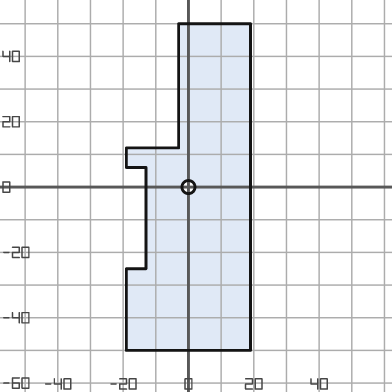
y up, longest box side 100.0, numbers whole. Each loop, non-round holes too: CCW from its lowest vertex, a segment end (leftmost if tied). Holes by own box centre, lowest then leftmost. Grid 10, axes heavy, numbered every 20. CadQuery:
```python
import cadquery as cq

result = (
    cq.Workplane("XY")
    .moveTo(-19.0, -50.0)
    .lineTo(19.0, -50.0)
    .lineTo(19.0, 50.0)
    .lineTo(-3.0, 50.0)
    .lineTo(-3.0, 12.0)
    .lineTo(-19.0, 12.0)
    .lineTo(-19.0, 6.0)
    .lineTo(-13.0, 6.0)
    .lineTo(-13.0, -25.0)
    .lineTo(-19.0, -25.0)
    .close()
    .moveTo(0.0, 0.0)
    .circle(2.0)
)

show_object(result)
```